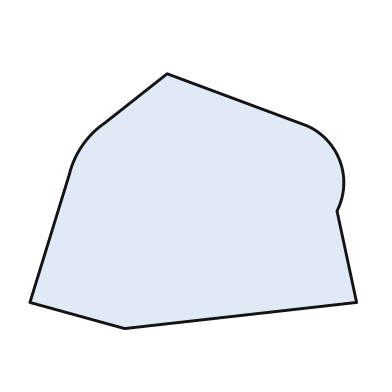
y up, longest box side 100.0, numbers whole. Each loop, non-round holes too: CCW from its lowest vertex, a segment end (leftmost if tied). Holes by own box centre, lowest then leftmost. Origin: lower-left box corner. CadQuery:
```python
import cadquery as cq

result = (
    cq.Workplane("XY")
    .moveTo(29.0, 0.0)
    .lineTo(100.0, 8.0)
    .lineTo(94.0, 36.0)
    .threePointArc((95.0, 51.0), (85.0, 62.0))
    .lineTo(42.0, 78.0)
    .lineTo(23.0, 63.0)
    .threePointArc((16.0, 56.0), (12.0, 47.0))
    .lineTo(0.0, 8.0)
    .close()
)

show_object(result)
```